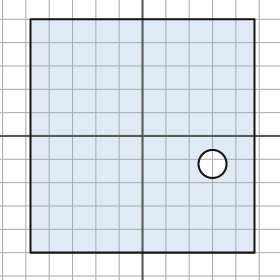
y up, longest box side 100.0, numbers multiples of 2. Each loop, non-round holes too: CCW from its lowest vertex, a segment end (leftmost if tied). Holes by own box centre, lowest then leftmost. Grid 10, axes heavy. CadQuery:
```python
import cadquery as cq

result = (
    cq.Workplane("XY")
    .moveTo(-48.0, -50.0)
    .lineTo(48.0, -50.0)
    .lineTo(48.0, 50.0)
    .lineTo(-48.0, 50.0)
    .close()
    .moveTo(30.0, -12.0)
    .circle(6.0)
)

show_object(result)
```